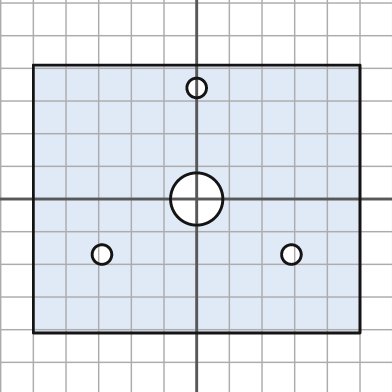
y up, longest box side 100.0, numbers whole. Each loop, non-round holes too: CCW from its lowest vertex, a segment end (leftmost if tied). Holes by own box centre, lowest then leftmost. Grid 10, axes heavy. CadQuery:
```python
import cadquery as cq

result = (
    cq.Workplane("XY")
    .moveTo(-50.0, -41.0)
    .lineTo(50.0, -41.0)
    .lineTo(50.0, 41.0)
    .lineTo(-50.0, 41.0)
    .close()
    .moveTo(-29.0, -17.0)
    .circle(3.0)
    .moveTo(29.0, -17.0)
    .circle(3.0)
    .moveTo(0.0, 0.0)
    .circle(8.0)
    .moveTo(0.0, 34.0)
    .circle(3.0)
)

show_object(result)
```